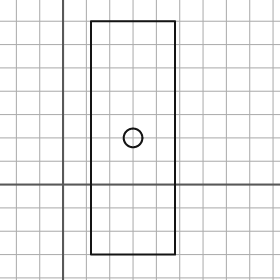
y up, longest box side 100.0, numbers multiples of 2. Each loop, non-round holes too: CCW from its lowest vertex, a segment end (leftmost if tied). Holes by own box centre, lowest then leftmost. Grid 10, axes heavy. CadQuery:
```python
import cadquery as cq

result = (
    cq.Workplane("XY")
    .moveTo(12.0, -30.0)
    .lineTo(48.0, -30.0)
    .lineTo(48.0, 70.0)
    .lineTo(12.0, 70.0)
    .close()
    .moveTo(30.0, 20.0)
    .circle(4.0)
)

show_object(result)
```